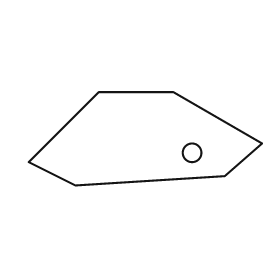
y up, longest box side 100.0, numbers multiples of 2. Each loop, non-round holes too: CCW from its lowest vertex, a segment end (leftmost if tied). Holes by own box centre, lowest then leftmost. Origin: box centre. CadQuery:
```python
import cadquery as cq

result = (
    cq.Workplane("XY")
    .moveTo(-30.0, -20.0)
    .lineTo(34.0, -16.0)
    .lineTo(50.0, -2.0)
    .lineTo(12.0, 20.0)
    .lineTo(-20.0, 20.0)
    .lineTo(-50.0, -10.0)
    .close()
    .moveTo(20.0, -6.0)
    .circle(4.0)
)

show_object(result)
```